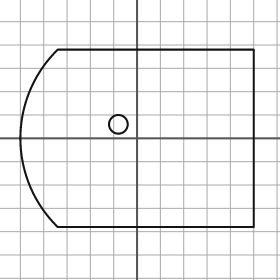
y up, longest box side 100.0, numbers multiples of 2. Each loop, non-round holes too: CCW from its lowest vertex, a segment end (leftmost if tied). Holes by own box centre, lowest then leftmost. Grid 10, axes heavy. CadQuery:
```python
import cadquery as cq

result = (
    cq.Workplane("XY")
    .moveTo(-34.0, -38.0)
    .lineTo(50.0, -38.0)
    .lineTo(50.0, 38.0)
    .lineTo(-34.0, 38.0)
    .threePointArc((-50.0, 0.0), (-34.0, -38.0))
    .close()
    .moveTo(-8.0, 6.0)
    .circle(4.0)
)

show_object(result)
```